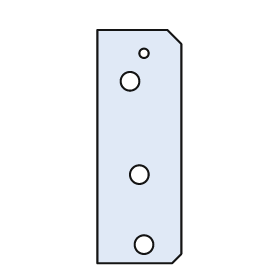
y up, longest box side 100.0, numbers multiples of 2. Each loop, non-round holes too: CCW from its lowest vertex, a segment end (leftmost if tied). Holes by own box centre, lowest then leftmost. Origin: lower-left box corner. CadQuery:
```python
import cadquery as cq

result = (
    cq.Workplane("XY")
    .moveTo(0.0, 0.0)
    .lineTo(32.0, 0.0)
    .lineTo(36.0, 4.0)
    .lineTo(36.0, 94.0)
    .lineTo(30.0, 100.0)
    .lineTo(0.0, 100.0)
    .close()
    .moveTo(20.0, 8.0)
    .circle(4.0)
    .moveTo(18.0, 38.0)
    .circle(4.0)
    .moveTo(14.0, 78.0)
    .circle(4.0)
    .moveTo(20.0, 90.0)
    .circle(2.0)
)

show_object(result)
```